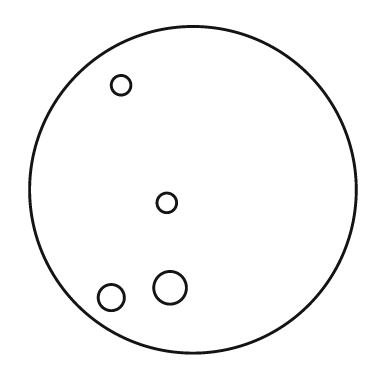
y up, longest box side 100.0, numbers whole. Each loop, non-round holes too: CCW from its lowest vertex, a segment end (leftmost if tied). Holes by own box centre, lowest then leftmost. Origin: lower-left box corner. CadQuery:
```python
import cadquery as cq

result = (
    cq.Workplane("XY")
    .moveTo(50.0, 50.0)
    .circle(50.0)
    .moveTo(25.0, 17.0)
    .circle(4.0)
    .moveTo(43.0, 20.0)
    .circle(5.0)
    .moveTo(42.0, 46.0)
    .circle(3.0)
    .moveTo(28.0, 82.0)
    .circle(3.0)
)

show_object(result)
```